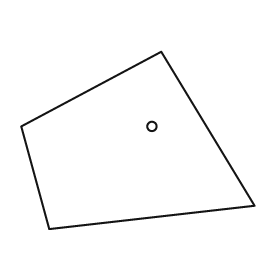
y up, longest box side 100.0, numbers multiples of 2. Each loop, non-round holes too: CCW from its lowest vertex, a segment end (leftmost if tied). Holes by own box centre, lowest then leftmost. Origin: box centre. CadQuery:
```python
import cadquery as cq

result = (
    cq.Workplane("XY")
    .moveTo(-38.0, -38.0)
    .lineTo(50.0, -28.0)
    .lineTo(10.0, 38.0)
    .lineTo(-50.0, 6.0)
    .close()
    .moveTo(6.0, 6.0)
    .circle(2.0)
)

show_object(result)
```